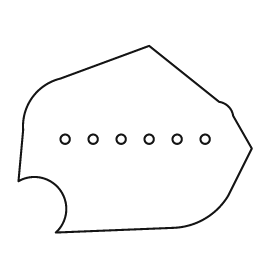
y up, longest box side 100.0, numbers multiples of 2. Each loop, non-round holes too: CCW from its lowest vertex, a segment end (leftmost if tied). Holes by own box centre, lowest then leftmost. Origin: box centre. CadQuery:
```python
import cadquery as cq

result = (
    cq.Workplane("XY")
    .moveTo(-34.0, -40.0)
    .lineTo(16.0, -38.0)
    .threePointArc((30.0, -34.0), (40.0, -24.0))
    .lineTo(50.0, -4.0)
    .lineTo(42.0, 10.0)
    .threePointArc((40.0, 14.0), (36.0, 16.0))
    .lineTo(6.0, 40.0)
    .lineTo(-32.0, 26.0)
    .threePointArc((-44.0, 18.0), (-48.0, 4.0))
    .lineTo(-50.0, -18.0)
    .threePointArc((-32.0, -22.0), (-34.0, -40.0))
    .close()
    .moveTo(-30.0, 0.0)
    .circle(2.0)
    .moveTo(-18.0, 0.0)
    .circle(2.0)
    .moveTo(-6.0, 0.0)
    .circle(2.0)
    .moveTo(6.0, 0.0)
    .circle(2.0)
    .moveTo(18.0, 0.0)
    .circle(2.0)
    .moveTo(30.0, 0.0)
    .circle(2.0)
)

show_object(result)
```